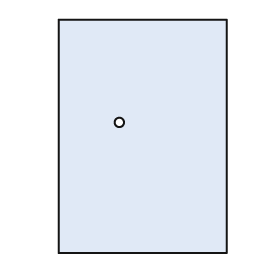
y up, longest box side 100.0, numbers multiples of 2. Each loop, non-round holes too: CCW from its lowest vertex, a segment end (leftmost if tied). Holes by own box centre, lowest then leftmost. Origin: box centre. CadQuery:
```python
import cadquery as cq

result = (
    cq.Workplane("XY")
    .moveTo(-36.0, -50.0)
    .lineTo(36.0, -50.0)
    .lineTo(36.0, 50.0)
    .lineTo(-36.0, 50.0)
    .close()
    .moveTo(-10.0, 6.0)
    .circle(2.0)
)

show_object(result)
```